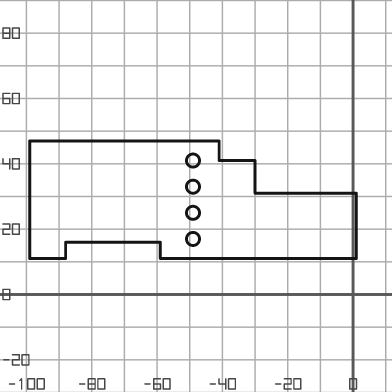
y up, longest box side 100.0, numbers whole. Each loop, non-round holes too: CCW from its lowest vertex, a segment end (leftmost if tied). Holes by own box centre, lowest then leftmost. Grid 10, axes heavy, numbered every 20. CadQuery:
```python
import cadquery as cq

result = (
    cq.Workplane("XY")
    .moveTo(-99.0, 11.0)
    .lineTo(-88.0, 11.0)
    .lineTo(-88.0, 16.0)
    .lineTo(-59.0, 16.0)
    .lineTo(-59.0, 11.0)
    .lineTo(1.0, 11.0)
    .lineTo(1.0, 31.0)
    .lineTo(-30.0, 31.0)
    .lineTo(-30.0, 41.0)
    .lineTo(-41.0, 41.0)
    .lineTo(-41.0, 47.0)
    .lineTo(-99.0, 47.0)
    .close()
    .moveTo(-49.0, 17.0)
    .circle(2.0)
    .moveTo(-49.0, 25.0)
    .circle(2.0)
    .moveTo(-49.0, 33.0)
    .circle(2.0)
    .moveTo(-49.0, 41.0)
    .circle(2.0)
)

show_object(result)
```